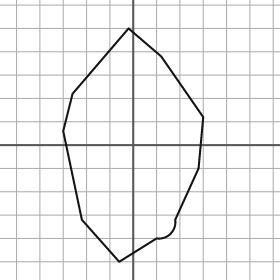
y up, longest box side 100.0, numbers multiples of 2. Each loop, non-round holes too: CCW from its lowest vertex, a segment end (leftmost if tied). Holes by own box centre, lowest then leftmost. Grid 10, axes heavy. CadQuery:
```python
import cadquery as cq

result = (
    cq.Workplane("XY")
    .moveTo(-6.0, -50.0)
    .lineTo(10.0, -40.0)
    .threePointArc((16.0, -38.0), (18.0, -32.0))
    .lineTo(28.0, -10.0)
    .lineTo(30.0, 12.0)
    .lineTo(12.0, 38.0)
    .lineTo(-2.0, 50.0)
    .lineTo(-26.0, 22.0)
    .lineTo(-30.0, 6.0)
    .lineTo(-22.0, -32.0)
    .close()
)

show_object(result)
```